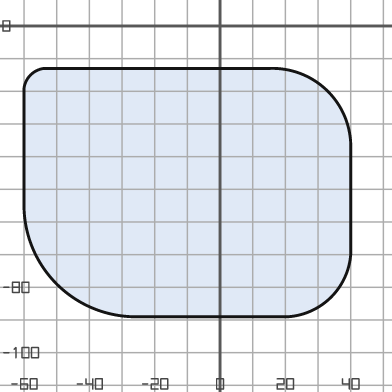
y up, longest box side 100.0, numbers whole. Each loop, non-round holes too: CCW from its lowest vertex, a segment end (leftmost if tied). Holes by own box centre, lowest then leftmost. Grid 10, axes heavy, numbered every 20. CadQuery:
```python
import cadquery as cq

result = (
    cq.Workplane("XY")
    .moveTo(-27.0, -89.0)
    .lineTo(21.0, -89.0)
    .threePointArc((34.0, -83.0), (40.0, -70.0))
    .lineTo(40.0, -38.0)
    .threePointArc((33.0, -20.0), (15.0, -13.0))
    .lineTo(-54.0, -13.0)
    .threePointArc((-58.0, -15.0), (-60.0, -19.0))
    .lineTo(-60.0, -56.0)
    .threePointArc((-50.0, -79.0), (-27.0, -89.0))
    .close()
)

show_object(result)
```